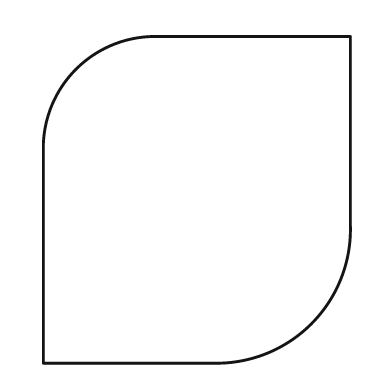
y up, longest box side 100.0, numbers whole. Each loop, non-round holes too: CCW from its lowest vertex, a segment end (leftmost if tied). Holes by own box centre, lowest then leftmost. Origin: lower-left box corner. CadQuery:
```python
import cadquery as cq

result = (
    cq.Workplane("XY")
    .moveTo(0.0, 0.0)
    .lineTo(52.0, 0.0)
    .threePointArc((82.0, 12.0), (94.0, 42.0))
    .lineTo(94.0, 100.0)
    .lineTo(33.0, 100.0)
    .threePointArc((10.0, 90.0), (0.0, 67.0))
    .close()
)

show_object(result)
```